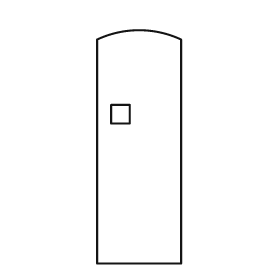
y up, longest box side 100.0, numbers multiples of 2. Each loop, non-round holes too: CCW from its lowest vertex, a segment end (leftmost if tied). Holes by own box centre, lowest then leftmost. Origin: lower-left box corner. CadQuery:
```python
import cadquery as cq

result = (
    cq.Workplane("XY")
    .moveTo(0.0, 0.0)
    .lineTo(36.0, 0.0)
    .lineTo(36.0, 96.0)
    .threePointArc((18.0, 100.0), (0.0, 96.0))
    .close()
    .moveTo(6.0, 60.0)
    .lineTo(14.0, 60.0)
    .lineTo(14.0, 68.0)
    .lineTo(6.0, 68.0)
    .close()
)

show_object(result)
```